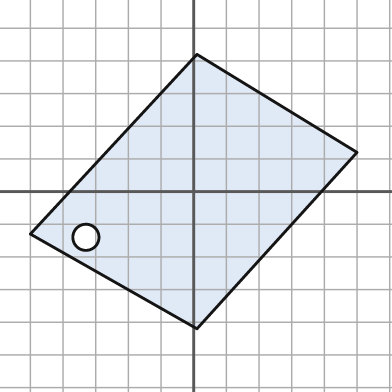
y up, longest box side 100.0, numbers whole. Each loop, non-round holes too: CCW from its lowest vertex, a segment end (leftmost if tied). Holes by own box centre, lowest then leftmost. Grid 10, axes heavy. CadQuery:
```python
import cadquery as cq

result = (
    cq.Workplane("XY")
    .moveTo(1.0, -42.0)
    .lineTo(50.0, 12.0)
    .lineTo(1.0, 42.0)
    .lineTo(-50.0, -13.0)
    .close()
    .moveTo(-33.0, -14.0)
    .circle(4.0)
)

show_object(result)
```